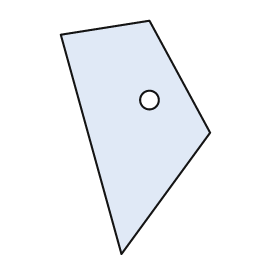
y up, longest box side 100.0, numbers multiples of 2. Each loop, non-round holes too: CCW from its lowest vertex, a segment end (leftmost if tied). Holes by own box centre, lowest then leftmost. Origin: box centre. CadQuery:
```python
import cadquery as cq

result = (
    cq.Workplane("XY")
    .moveTo(-6.0, -50.0)
    .lineTo(32.0, 2.0)
    .lineTo(6.0, 50.0)
    .lineTo(-32.0, 44.0)
    .close()
    .moveTo(6.0, 16.0)
    .circle(4.0)
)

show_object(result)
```